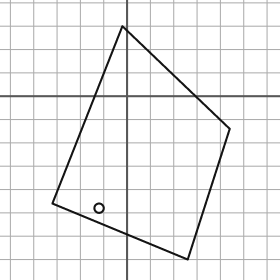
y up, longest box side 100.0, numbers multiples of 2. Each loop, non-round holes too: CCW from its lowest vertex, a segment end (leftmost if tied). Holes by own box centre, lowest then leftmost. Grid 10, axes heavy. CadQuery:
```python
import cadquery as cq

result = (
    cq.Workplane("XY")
    .moveTo(26.0, -70.0)
    .lineTo(44.0, -14.0)
    .lineTo(-2.0, 30.0)
    .lineTo(-32.0, -46.0)
    .close()
    .moveTo(-12.0, -48.0)
    .circle(2.0)
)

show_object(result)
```